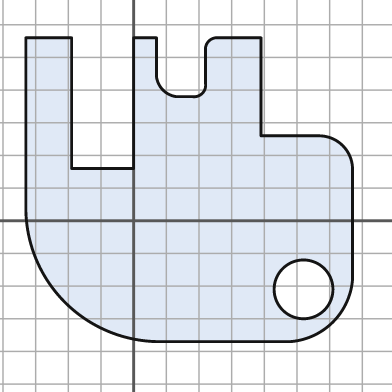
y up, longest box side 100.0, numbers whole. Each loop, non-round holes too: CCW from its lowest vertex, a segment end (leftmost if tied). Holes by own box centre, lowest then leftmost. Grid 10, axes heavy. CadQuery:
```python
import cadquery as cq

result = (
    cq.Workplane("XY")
    .moveTo(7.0, -37.0)
    .lineTo(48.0, -37.0)
    .threePointArc((61.0, -31.0), (67.0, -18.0))
    .lineTo(67.0, 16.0)
    .threePointArc((64.0, 23.0), (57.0, 26.0))
    .lineTo(39.0, 26.0)
    .lineTo(39.0, 56.0)
    .lineTo(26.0, 56.0)
    .threePointArc((23.0, 55.0), (22.0, 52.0))
    .lineTo(22.0, 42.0)
    .threePointArc((21.0, 39.0), (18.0, 38.0))
    .lineTo(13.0, 38.0)
    .threePointArc((9.0, 40.0), (7.0, 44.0))
    .lineTo(7.0, 56.0)
    .lineTo(0.0, 56.0)
    .lineTo(0.0, 16.0)
    .lineTo(-19.0, 16.0)
    .lineTo(-19.0, 56.0)
    .lineTo(-33.0, 56.0)
    .lineTo(-33.0, 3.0)
    .threePointArc((-21.0, -25.0), (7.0, -37.0))
    .close()
    .moveTo(52.0, -21.0)
    .circle(9.0)
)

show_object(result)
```